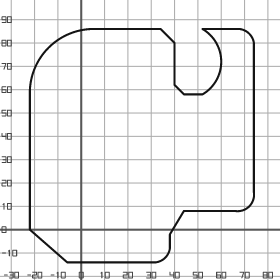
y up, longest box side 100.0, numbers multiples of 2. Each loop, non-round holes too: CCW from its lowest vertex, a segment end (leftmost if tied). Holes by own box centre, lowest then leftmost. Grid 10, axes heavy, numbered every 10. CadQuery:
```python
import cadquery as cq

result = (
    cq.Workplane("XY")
    .moveTo(-6.0, -14.0)
    .lineTo(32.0, -14.0)
    .threePointArc((36.0, -12.0), (38.0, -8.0))
    .lineTo(38.0, -2.0)
    .lineTo(44.0, 8.0)
    .lineTo(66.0, 8.0)
    .threePointArc((72.0, 10.0), (74.0, 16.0))
    .lineTo(74.0, 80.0)
    .threePointArc((72.0, 84.0), (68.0, 86.0))
    .lineTo(52.0, 86.0)
    .threePointArc((60.0, 72.0), (52.0, 58.0))
    .lineTo(44.0, 58.0)
    .lineTo(40.0, 62.0)
    .lineTo(40.0, 80.0)
    .lineTo(34.0, 86.0)
    .lineTo(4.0, 86.0)
    .threePointArc((-14.0, 78.0), (-22.0, 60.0))
    .lineTo(-22.0, 0.0)
    .close()
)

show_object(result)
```